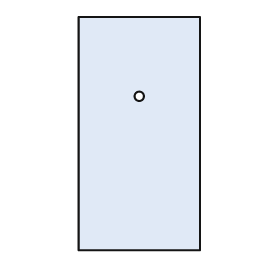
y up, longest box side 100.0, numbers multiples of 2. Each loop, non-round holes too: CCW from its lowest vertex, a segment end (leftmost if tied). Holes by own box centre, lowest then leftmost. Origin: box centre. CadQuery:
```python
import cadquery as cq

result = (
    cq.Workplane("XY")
    .moveTo(-26.0, -50.0)
    .lineTo(26.0, -50.0)
    .lineTo(26.0, 50.0)
    .lineTo(-26.0, 50.0)
    .close()
    .moveTo(0.0, 16.0)
    .circle(2.0)
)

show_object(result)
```